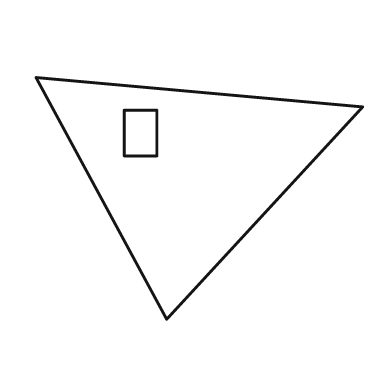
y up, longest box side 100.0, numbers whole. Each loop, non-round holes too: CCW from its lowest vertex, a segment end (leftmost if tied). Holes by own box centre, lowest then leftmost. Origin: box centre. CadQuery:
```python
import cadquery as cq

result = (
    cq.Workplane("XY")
    .moveTo(-10.0, -37.0)
    .lineTo(50.0, 28.0)
    .lineTo(-50.0, 37.0)
    .close()
    .moveTo(-23.0, 13.0)
    .lineTo(-13.0, 13.0)
    .lineTo(-13.0, 27.0)
    .lineTo(-23.0, 27.0)
    .close()
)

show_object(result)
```